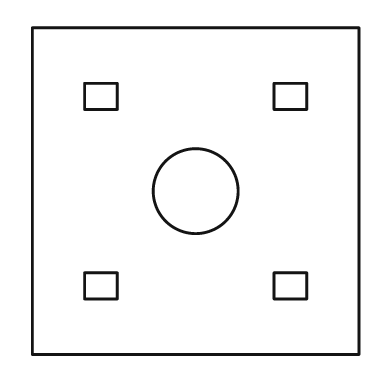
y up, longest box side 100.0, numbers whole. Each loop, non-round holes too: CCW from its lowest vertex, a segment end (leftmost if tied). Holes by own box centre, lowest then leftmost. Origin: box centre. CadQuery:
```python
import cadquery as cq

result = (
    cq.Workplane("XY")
    .moveTo(-50.0, -50.0)
    .lineTo(50.0, -50.0)
    .lineTo(50.0, 50.0)
    .lineTo(-50.0, 50.0)
    .close()
    .moveTo(-34.0, -33.0)
    .lineTo(-24.0, -33.0)
    .lineTo(-24.0, -25.0)
    .lineTo(-34.0, -25.0)
    .close()
    .moveTo(24.0, -33.0)
    .lineTo(34.0, -33.0)
    .lineTo(34.0, -25.0)
    .lineTo(24.0, -25.0)
    .close()
    .moveTo(0.0, 0.0)
    .circle(13.0)
    .moveTo(-34.0, 25.0)
    .lineTo(-24.0, 25.0)
    .lineTo(-24.0, 33.0)
    .lineTo(-34.0, 33.0)
    .close()
    .moveTo(24.0, 25.0)
    .lineTo(34.0, 25.0)
    .lineTo(34.0, 33.0)
    .lineTo(24.0, 33.0)
    .close()
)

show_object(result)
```